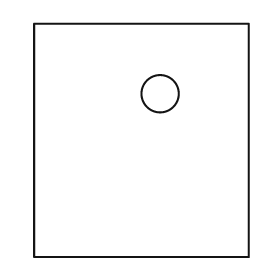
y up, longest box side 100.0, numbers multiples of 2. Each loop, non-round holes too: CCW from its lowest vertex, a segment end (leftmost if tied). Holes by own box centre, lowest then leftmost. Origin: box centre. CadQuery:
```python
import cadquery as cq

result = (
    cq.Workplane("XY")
    .moveTo(-46.0, -50.0)
    .lineTo(46.0, -50.0)
    .lineTo(46.0, 50.0)
    .lineTo(-46.0, 50.0)
    .close()
    .moveTo(8.0, 20.0)
    .circle(8.0)
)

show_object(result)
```